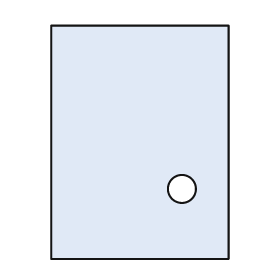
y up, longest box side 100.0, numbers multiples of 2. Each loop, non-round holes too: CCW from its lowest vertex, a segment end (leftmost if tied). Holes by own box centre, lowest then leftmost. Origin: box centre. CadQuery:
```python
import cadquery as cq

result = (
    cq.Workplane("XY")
    .moveTo(-38.0, -50.0)
    .lineTo(38.0, -50.0)
    .lineTo(38.0, 50.0)
    .lineTo(-38.0, 50.0)
    .close()
    .moveTo(18.0, -20.0)
    .circle(6.0)
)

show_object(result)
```